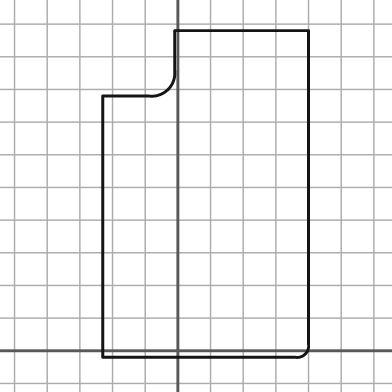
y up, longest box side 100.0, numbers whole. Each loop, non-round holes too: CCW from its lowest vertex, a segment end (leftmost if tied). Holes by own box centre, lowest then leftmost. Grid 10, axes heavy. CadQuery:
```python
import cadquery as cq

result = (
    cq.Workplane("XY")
    .moveTo(-23.0, -2.0)
    .lineTo(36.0, -2.0)
    .threePointArc((39.0, -1.0), (40.0, 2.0))
    .lineTo(40.0, 98.0)
    .lineTo(-1.0, 98.0)
    .lineTo(-1.0, 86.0)
    .threePointArc((-3.0, 80.0), (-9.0, 78.0))
    .lineTo(-23.0, 78.0)
    .close()
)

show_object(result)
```